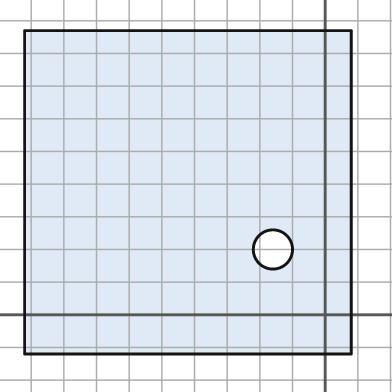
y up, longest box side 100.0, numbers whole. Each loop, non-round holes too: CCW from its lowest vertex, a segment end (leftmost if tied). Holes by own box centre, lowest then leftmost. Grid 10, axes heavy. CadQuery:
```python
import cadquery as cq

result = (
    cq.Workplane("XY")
    .moveTo(-92.0, -12.0)
    .lineTo(8.0, -12.0)
    .lineTo(8.0, 87.0)
    .lineTo(-92.0, 87.0)
    .close()
    .moveTo(-16.0, 20.0)
    .circle(6.0)
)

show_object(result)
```